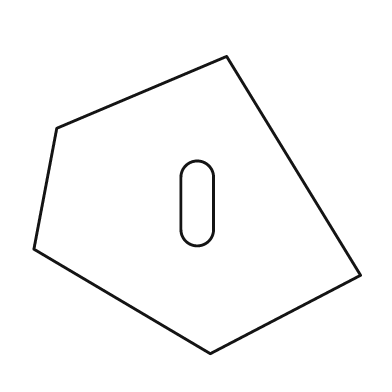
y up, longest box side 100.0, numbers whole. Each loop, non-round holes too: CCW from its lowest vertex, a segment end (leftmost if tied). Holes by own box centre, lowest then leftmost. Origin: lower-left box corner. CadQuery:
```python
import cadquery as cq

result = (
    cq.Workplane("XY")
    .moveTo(54.0, 0.0)
    .lineTo(100.0, 24.0)
    .lineTo(59.0, 91.0)
    .lineTo(7.0, 69.0)
    .lineTo(0.0, 32.0)
    .close()
    .moveTo(45.0, 38.0)
    .threePointArc((50.0, 33.0), (55.0, 38.0))
    .lineTo(55.0, 54.0)
    .threePointArc((50.0, 59.0), (45.0, 54.0))
    .close()
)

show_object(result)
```